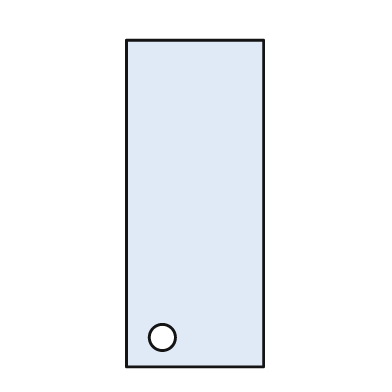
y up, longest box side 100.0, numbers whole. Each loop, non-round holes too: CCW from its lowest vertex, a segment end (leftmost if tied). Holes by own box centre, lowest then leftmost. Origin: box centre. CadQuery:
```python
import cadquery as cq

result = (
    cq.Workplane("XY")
    .moveTo(-21.0, -50.0)
    .lineTo(21.0, -50.0)
    .lineTo(21.0, 50.0)
    .lineTo(-21.0, 50.0)
    .close()
    .moveTo(-10.0, -41.0)
    .circle(4.0)
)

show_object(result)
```